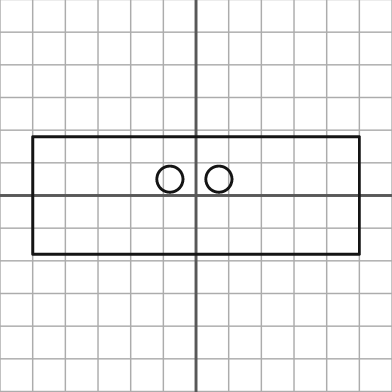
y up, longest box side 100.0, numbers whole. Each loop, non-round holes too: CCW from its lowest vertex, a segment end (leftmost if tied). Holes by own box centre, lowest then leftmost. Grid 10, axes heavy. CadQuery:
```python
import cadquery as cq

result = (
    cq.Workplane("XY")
    .moveTo(-50.0, -18.0)
    .lineTo(50.0, -18.0)
    .lineTo(50.0, 18.0)
    .lineTo(-50.0, 18.0)
    .close()
    .moveTo(-8.0, 5.0)
    .circle(4.0)
    .moveTo(7.0, 5.0)
    .circle(4.0)
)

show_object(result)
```